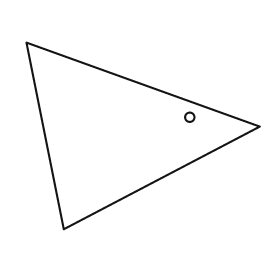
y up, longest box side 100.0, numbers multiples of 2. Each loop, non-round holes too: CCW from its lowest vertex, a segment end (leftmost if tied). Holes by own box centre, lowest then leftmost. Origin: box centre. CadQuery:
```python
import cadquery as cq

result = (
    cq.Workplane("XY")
    .moveTo(-34.0, -40.0)
    .lineTo(50.0, 4.0)
    .lineTo(-50.0, 40.0)
    .close()
    .moveTo(20.0, 8.0)
    .circle(2.0)
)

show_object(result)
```